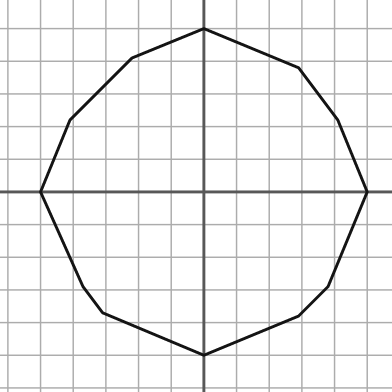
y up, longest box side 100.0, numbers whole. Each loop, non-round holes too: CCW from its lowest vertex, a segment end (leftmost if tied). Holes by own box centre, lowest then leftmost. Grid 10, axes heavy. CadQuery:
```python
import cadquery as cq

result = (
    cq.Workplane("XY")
    .moveTo(0.0, -50.0)
    .lineTo(29.0, -38.0)
    .lineTo(38.0, -29.0)
    .lineTo(50.0, 0.0)
    .lineTo(41.0, 22.0)
    .lineTo(29.0, 38.0)
    .lineTo(0.0, 50.0)
    .lineTo(-22.0, 41.0)
    .lineTo(-41.0, 22.0)
    .lineTo(-50.0, 0.0)
    .lineTo(-37.0, -29.0)
    .lineTo(-31.0, -37.0)
    .close()
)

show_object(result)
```